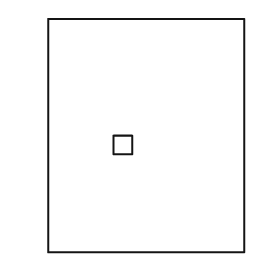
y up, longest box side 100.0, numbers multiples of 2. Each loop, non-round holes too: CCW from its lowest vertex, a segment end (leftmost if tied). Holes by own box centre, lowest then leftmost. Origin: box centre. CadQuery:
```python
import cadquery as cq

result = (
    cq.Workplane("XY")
    .moveTo(-42.0, -50.0)
    .lineTo(42.0, -50.0)
    .lineTo(42.0, 50.0)
    .lineTo(-42.0, 50.0)
    .close()
    .moveTo(-14.0, -8.0)
    .lineTo(-6.0, -8.0)
    .lineTo(-6.0, 0.0)
    .lineTo(-14.0, 0.0)
    .close()
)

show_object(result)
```